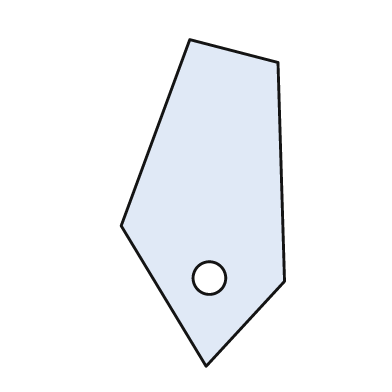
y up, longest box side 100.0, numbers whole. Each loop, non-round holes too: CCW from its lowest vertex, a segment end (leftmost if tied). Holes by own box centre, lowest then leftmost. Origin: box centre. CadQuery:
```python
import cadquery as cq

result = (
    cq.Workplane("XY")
    .moveTo(1.0, -50.0)
    .lineTo(25.0, -24.0)
    .lineTo(23.0, 43.0)
    .lineTo(-4.0, 50.0)
    .lineTo(-25.0, -7.0)
    .close()
    .moveTo(2.0, -23.0)
    .circle(5.0)
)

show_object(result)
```